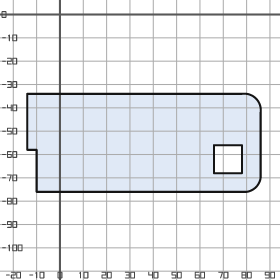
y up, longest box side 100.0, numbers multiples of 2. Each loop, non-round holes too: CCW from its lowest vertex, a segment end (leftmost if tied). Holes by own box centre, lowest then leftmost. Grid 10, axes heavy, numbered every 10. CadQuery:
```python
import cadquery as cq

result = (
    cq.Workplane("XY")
    .moveTo(-10.0, -76.0)
    .lineTo(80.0, -76.0)
    .threePointArc((84.0, -74.0), (86.0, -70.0))
    .lineTo(86.0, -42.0)
    .threePointArc((84.0, -36.0), (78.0, -34.0))
    .lineTo(-14.0, -34.0)
    .lineTo(-14.0, -58.0)
    .lineTo(-10.0, -58.0)
    .close()
    .moveTo(66.0, -68.0)
    .lineTo(78.0, -68.0)
    .lineTo(78.0, -56.0)
    .lineTo(66.0, -56.0)
    .close()
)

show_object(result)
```